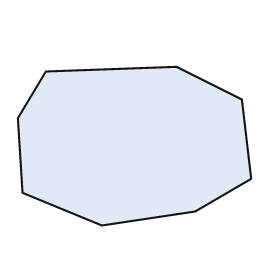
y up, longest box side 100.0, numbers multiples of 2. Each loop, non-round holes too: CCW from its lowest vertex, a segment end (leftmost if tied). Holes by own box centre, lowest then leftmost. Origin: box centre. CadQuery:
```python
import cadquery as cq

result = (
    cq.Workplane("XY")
    .moveTo(-14.0, -34.0)
    .lineTo(26.0, -28.0)
    .lineTo(50.0, -14.0)
    .lineTo(46.0, 20.0)
    .lineTo(18.0, 34.0)
    .lineTo(-38.0, 32.0)
    .lineTo(-50.0, 12.0)
    .lineTo(-48.0, -20.0)
    .close()
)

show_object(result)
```